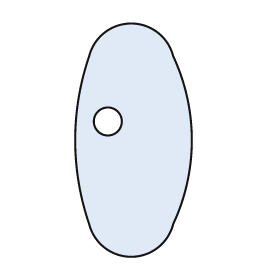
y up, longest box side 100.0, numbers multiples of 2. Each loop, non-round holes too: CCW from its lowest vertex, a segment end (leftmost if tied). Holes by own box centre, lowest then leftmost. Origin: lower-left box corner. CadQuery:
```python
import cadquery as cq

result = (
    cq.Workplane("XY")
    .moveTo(6.0, 14.0)
    .threePointArc((24.0, 0.0), (42.0, 14.0))
    .threePointArc((50.0, 50.0), (42.0, 86.0))
    .threePointArc((24.0, 100.0), (6.0, 86.0))
    .threePointArc((0.0, 50.0), (6.0, 14.0))
    .close()
    .moveTo(14.0, 58.0)
    .circle(6.0)
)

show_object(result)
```